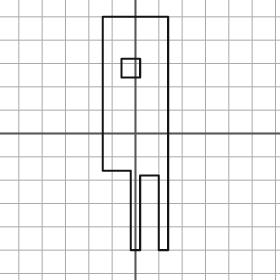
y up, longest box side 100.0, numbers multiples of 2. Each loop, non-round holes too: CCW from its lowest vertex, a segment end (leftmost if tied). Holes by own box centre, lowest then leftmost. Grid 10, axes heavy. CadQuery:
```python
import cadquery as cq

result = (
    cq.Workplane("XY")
    .moveTo(-2.0, -50.0)
    .lineTo(2.0, -50.0)
    .lineTo(2.0, -18.0)
    .lineTo(10.0, -18.0)
    .lineTo(10.0, -50.0)
    .lineTo(14.0, -50.0)
    .lineTo(14.0, 50.0)
    .lineTo(-14.0, 50.0)
    .lineTo(-14.0, -16.0)
    .lineTo(-2.0, -16.0)
    .close()
    .moveTo(-6.0, 24.0)
    .lineTo(2.0, 24.0)
    .lineTo(2.0, 32.0)
    .lineTo(-6.0, 32.0)
    .close()
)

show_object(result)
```